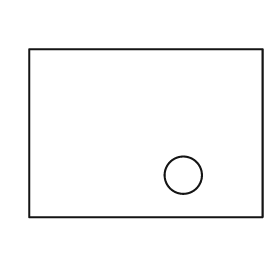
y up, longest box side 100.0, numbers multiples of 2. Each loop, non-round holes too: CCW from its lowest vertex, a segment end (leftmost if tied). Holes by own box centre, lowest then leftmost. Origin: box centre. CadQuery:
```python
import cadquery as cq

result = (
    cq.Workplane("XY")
    .moveTo(-50.0, -36.0)
    .lineTo(50.0, -36.0)
    .lineTo(50.0, 36.0)
    .lineTo(-50.0, 36.0)
    .close()
    .moveTo(16.0, -18.0)
    .circle(8.0)
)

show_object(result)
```